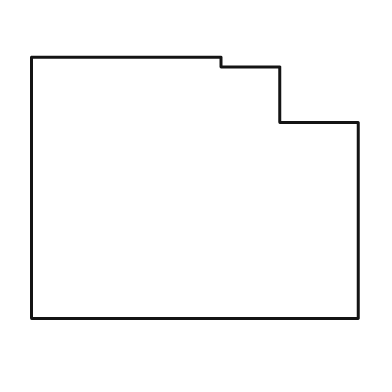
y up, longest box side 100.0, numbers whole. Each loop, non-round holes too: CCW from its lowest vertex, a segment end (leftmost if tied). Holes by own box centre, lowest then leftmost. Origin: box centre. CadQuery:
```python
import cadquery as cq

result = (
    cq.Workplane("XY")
    .moveTo(-50.0, -40.0)
    .lineTo(50.0, -40.0)
    .lineTo(50.0, 20.0)
    .lineTo(26.0, 20.0)
    .lineTo(26.0, 37.0)
    .lineTo(8.0, 37.0)
    .lineTo(8.0, 40.0)
    .lineTo(-50.0, 40.0)
    .close()
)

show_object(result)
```